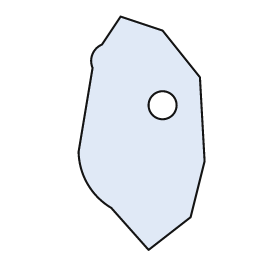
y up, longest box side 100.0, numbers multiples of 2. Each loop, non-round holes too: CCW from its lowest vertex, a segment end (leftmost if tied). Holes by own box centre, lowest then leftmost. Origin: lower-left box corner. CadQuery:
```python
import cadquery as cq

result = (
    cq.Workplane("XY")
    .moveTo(30.0, 0.0)
    .lineTo(48.0, 14.0)
    .lineTo(54.0, 38.0)
    .lineTo(52.0, 74.0)
    .lineTo(36.0, 94.0)
    .lineTo(18.0, 100.0)
    .lineTo(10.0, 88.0)
    .threePointArc((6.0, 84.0), (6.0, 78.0))
    .lineTo(0.0, 42.0)
    .threePointArc((4.0, 28.0), (14.0, 18.0))
    .close()
    .moveTo(36.0, 62.0)
    .circle(6.0)
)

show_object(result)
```